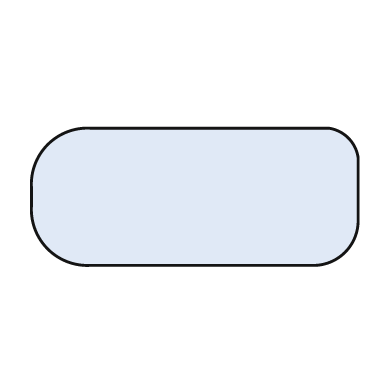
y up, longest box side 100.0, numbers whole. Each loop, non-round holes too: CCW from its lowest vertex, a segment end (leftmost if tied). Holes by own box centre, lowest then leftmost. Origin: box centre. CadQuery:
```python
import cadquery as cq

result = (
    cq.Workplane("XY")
    .moveTo(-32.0, -21.0)
    .lineTo(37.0, -21.0)
    .threePointArc((46.0, -17.0), (50.0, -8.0))
    .lineTo(50.0, 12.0)
    .threePointArc((47.0, 18.0), (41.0, 21.0))
    .lineTo(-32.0, 21.0)
    .threePointArc((-45.0, 16.0), (-50.0, 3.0))
    .lineTo(-50.0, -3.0)
    .threePointArc((-45.0, -16.0), (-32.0, -21.0))
    .close()
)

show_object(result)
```